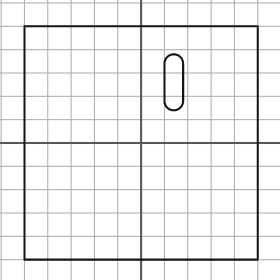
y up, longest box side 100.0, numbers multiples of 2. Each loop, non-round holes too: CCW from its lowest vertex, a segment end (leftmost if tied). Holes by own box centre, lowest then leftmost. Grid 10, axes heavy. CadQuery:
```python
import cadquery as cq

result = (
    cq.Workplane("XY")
    .moveTo(-50.0, -50.0)
    .lineTo(50.0, -50.0)
    .lineTo(50.0, 50.0)
    .lineTo(-50.0, 50.0)
    .close()
    .moveTo(10.0, 18.0)
    .threePointArc((14.0, 14.0), (18.0, 18.0))
    .lineTo(18.0, 34.0)
    .threePointArc((14.0, 38.0), (10.0, 34.0))
    .close()
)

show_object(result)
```